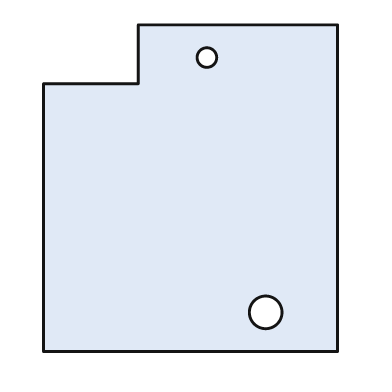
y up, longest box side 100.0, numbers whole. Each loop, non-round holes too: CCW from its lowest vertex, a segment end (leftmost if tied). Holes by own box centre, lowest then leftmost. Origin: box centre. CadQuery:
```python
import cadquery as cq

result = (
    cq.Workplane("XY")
    .moveTo(-45.0, -50.0)
    .lineTo(45.0, -50.0)
    .lineTo(45.0, 50.0)
    .lineTo(-16.0, 50.0)
    .lineTo(-16.0, 32.0)
    .lineTo(-45.0, 32.0)
    .close()
    .moveTo(23.0, -38.0)
    .circle(5.0)
    .moveTo(5.0, 40.0)
    .circle(3.0)
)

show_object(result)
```